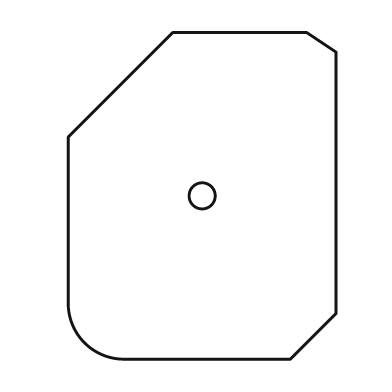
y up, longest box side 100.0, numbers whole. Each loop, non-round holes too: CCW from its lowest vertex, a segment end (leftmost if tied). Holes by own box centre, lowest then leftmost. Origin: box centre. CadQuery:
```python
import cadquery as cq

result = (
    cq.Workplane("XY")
    .moveTo(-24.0, -50.0)
    .lineTo(27.0, -50.0)
    .lineTo(41.0, -36.0)
    .lineTo(41.0, 44.0)
    .lineTo(32.0, 50.0)
    .lineTo(-9.0, 50.0)
    .lineTo(-41.0, 18.0)
    .lineTo(-41.0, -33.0)
    .threePointArc((-36.0, -45.0), (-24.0, -50.0))
    .close()
    .moveTo(0.0, 0.0)
    .circle(4.0)
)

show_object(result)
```